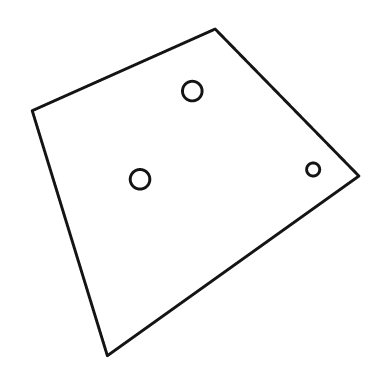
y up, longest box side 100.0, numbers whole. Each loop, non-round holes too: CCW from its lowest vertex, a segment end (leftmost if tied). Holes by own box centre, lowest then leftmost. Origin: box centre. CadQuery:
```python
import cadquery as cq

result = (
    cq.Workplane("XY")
    .moveTo(-27.0, -50.0)
    .lineTo(50.0, 5.0)
    .lineTo(6.0, 50.0)
    .lineTo(-50.0, 25.0)
    .close()
    .moveTo(-17.0, 4.0)
    .circle(3.0)
    .moveTo(36.0, 7.0)
    .circle(2.0)
    .moveTo(-1.0, 31.0)
    .circle(3.0)
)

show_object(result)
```